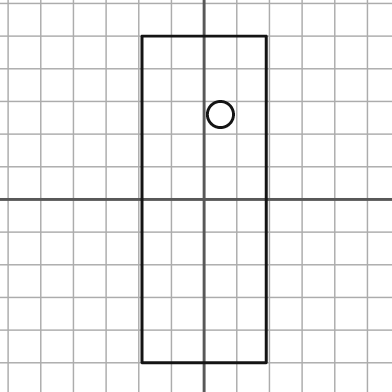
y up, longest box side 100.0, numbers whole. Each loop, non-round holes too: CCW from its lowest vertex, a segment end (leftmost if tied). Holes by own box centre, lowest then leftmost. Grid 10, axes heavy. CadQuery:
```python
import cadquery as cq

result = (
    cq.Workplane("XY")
    .moveTo(-19.0, -50.0)
    .lineTo(19.0, -50.0)
    .lineTo(19.0, 50.0)
    .lineTo(-19.0, 50.0)
    .close()
    .moveTo(5.0, 26.0)
    .circle(4.0)
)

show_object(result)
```